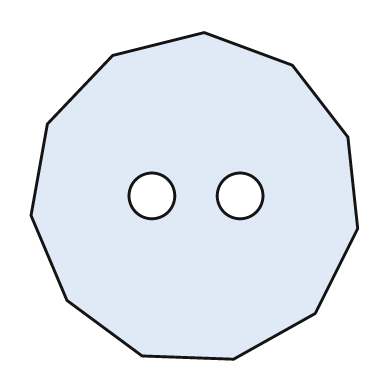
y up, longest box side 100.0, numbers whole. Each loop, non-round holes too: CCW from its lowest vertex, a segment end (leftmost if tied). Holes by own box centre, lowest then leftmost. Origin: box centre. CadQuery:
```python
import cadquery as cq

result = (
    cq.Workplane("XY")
    .moveTo(12.0, -50.0)
    .lineTo(37.0, -36.0)
    .lineTo(50.0, -10.0)
    .lineTo(47.0, 18.0)
    .lineTo(30.0, 40.0)
    .lineTo(3.0, 50.0)
    .lineTo(-25.0, 43.0)
    .lineTo(-45.0, 22.0)
    .lineTo(-50.0, -6.0)
    .lineTo(-39.0, -32.0)
    .lineTo(-16.0, -49.0)
    .close()
    .moveTo(-13.0, 0.0)
    .circle(7.0)
    .moveTo(14.0, 0.0)
    .circle(7.0)
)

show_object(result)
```